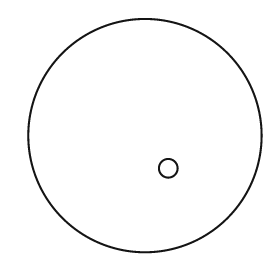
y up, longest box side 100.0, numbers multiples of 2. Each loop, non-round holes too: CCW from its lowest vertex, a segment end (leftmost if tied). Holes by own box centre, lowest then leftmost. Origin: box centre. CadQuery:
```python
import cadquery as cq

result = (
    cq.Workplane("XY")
    .moveTo(0.0, 0.0)
    .circle(50.0)
    .moveTo(10.0, -14.0)
    .circle(4.0)
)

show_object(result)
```